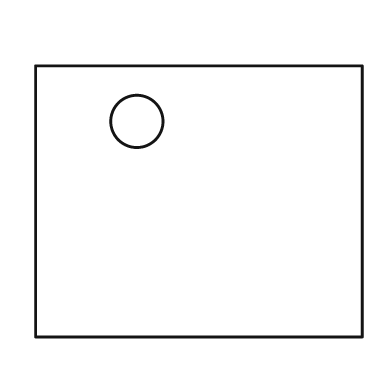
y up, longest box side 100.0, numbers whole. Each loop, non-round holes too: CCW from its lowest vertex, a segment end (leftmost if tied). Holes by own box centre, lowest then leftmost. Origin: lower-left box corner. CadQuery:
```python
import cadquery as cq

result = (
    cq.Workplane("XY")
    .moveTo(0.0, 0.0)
    .lineTo(100.0, 0.0)
    .lineTo(100.0, 83.0)
    .lineTo(0.0, 83.0)
    .close()
    .moveTo(31.0, 66.0)
    .circle(8.0)
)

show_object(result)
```